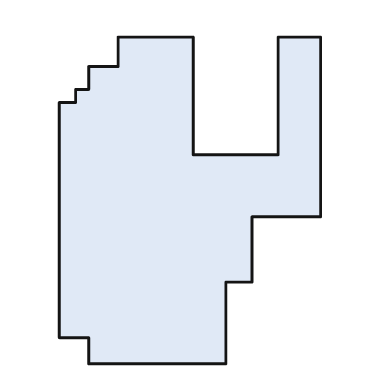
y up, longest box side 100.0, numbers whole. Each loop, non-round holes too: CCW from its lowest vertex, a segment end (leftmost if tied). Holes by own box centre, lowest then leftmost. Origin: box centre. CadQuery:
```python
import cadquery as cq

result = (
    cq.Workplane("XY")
    .moveTo(-31.0, -50.0)
    .lineTo(11.0, -50.0)
    .lineTo(11.0, -25.0)
    .lineTo(19.0, -25.0)
    .lineTo(19.0, -5.0)
    .lineTo(40.0, -5.0)
    .lineTo(40.0, 50.0)
    .lineTo(27.0, 50.0)
    .lineTo(27.0, 14.0)
    .lineTo(1.0, 14.0)
    .lineTo(1.0, 50.0)
    .lineTo(-22.0, 50.0)
    .lineTo(-22.0, 41.0)
    .lineTo(-31.0, 41.0)
    .lineTo(-31.0, 34.0)
    .lineTo(-35.0, 34.0)
    .lineTo(-35.0, 30.0)
    .lineTo(-40.0, 30.0)
    .lineTo(-40.0, -42.0)
    .lineTo(-31.0, -42.0)
    .close()
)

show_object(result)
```